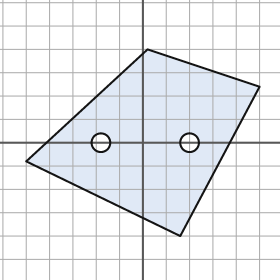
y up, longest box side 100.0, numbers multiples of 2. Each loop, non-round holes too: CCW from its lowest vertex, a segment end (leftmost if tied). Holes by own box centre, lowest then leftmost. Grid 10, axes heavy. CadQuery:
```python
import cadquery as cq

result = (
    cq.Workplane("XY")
    .moveTo(16.0, -40.0)
    .lineTo(50.0, 24.0)
    .lineTo(2.0, 40.0)
    .lineTo(-50.0, -8.0)
    .close()
    .moveTo(-18.0, 0.0)
    .circle(4.0)
    .moveTo(20.0, 0.0)
    .circle(4.0)
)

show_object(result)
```